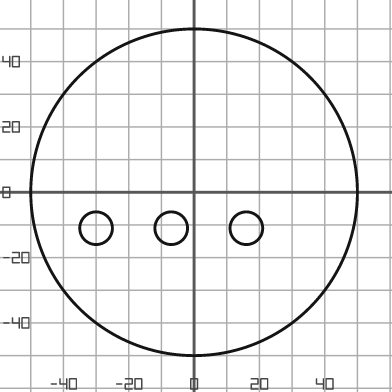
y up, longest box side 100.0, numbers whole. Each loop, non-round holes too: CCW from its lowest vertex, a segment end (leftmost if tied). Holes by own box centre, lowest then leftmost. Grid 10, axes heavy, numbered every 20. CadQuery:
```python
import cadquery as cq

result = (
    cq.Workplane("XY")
    .moveTo(0.0, 0.0)
    .circle(50.0)
    .moveTo(-30.0, -11.0)
    .circle(5.0)
    .moveTo(-7.0, -11.0)
    .circle(5.0)
    .moveTo(16.0, -11.0)
    .circle(5.0)
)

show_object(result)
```